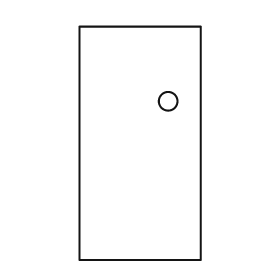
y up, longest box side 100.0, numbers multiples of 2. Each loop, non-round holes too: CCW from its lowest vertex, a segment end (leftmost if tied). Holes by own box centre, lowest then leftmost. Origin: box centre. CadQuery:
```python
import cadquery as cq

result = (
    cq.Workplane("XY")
    .moveTo(-26.0, -50.0)
    .lineTo(26.0, -50.0)
    .lineTo(26.0, 50.0)
    .lineTo(-26.0, 50.0)
    .close()
    .moveTo(12.0, 18.0)
    .circle(4.0)
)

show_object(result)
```